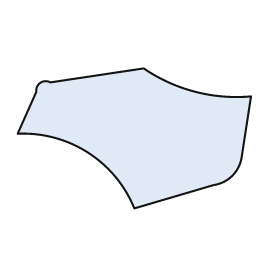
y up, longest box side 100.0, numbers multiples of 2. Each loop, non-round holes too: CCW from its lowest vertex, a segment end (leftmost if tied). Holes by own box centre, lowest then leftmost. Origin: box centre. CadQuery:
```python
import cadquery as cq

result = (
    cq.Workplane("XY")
    .moveTo(0.0, -30.0)
    .lineTo(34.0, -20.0)
    .threePointArc((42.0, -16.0), (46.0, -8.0))
    .lineTo(50.0, 18.0)
    .threePointArc((26.0, 20.0), (4.0, 30.0))
    .lineTo(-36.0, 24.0)
    .threePointArc((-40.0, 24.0), (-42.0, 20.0))
    .lineTo(-50.0, 2.0)
    .threePointArc((-20.0, -6.0), (0.0, -30.0))
    .close()
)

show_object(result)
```